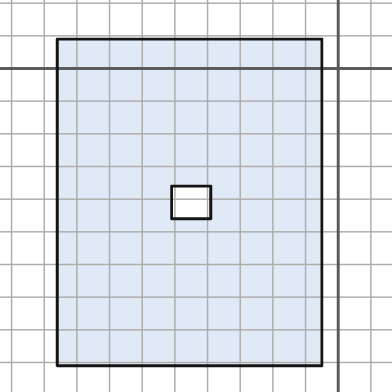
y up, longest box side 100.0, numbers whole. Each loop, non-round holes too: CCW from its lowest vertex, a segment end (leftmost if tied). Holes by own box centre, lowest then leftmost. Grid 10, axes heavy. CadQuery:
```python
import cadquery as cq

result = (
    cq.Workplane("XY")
    .moveTo(-86.0, -91.0)
    .lineTo(-5.0, -91.0)
    .lineTo(-5.0, 9.0)
    .lineTo(-86.0, 9.0)
    .close()
    .moveTo(-51.0, -46.0)
    .lineTo(-39.0, -46.0)
    .lineTo(-39.0, -36.0)
    .lineTo(-51.0, -36.0)
    .close()
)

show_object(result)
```